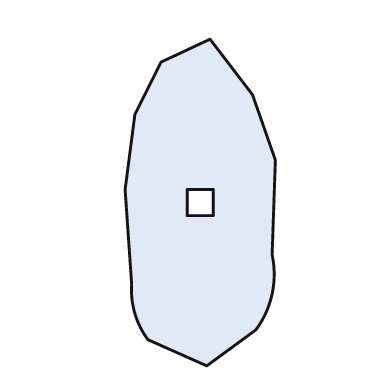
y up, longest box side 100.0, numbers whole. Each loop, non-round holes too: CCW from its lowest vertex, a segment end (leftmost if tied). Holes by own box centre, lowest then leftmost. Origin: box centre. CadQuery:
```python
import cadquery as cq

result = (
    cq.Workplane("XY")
    .moveTo(2.0, -50.0)
    .lineTo(17.0, -39.0)
    .threePointArc((22.0, -28.0), (22.0, -16.0))
    .lineTo(23.0, 13.0)
    .lineTo(16.0, 33.0)
    .lineTo(3.0, 50.0)
    .lineTo(-12.0, 43.0)
    .lineTo(-20.0, 27.0)
    .lineTo(-23.0, 4.0)
    .lineTo(-21.0, -25.0)
    .threePointArc((-20.0, -34.0), (-16.0, -42.0))
    .close()
    .moveTo(-4.0, -4.0)
    .lineTo(4.0, -4.0)
    .lineTo(4.0, 4.0)
    .lineTo(-4.0, 4.0)
    .close()
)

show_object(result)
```